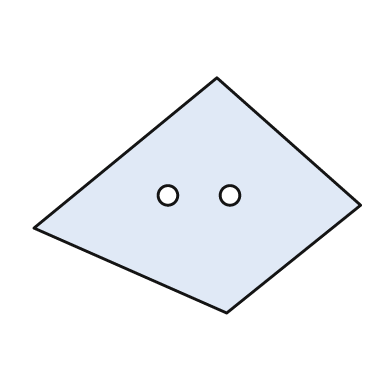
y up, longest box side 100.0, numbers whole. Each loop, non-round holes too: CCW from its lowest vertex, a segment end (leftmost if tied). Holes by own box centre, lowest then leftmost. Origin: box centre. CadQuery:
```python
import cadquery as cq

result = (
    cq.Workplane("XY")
    .moveTo(9.0, -36.0)
    .lineTo(50.0, -3.0)
    .lineTo(6.0, 36.0)
    .lineTo(-50.0, -10.0)
    .close()
    .moveTo(-9.0, 0.0)
    .circle(3.0)
    .moveTo(10.0, 0.0)
    .circle(3.0)
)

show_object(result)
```